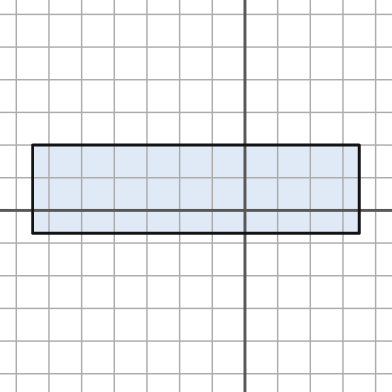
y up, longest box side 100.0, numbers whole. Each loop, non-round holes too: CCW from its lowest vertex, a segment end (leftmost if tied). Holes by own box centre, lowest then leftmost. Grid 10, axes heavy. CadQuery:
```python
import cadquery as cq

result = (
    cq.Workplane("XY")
    .moveTo(-65.0, -7.0)
    .lineTo(35.0, -7.0)
    .lineTo(35.0, 20.0)
    .lineTo(-65.0, 20.0)
    .close()
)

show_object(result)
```